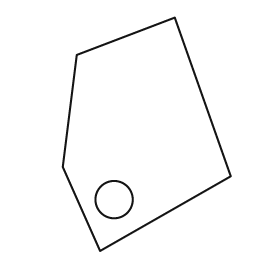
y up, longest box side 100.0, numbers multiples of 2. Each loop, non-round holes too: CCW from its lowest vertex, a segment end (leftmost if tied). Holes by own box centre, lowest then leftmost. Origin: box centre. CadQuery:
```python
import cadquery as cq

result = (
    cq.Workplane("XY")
    .moveTo(-20.0, -50.0)
    .lineTo(36.0, -18.0)
    .lineTo(12.0, 50.0)
    .lineTo(-30.0, 34.0)
    .lineTo(-36.0, -14.0)
    .close()
    .moveTo(-14.0, -28.0)
    .circle(8.0)
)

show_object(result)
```